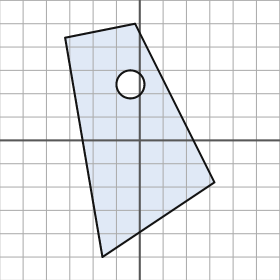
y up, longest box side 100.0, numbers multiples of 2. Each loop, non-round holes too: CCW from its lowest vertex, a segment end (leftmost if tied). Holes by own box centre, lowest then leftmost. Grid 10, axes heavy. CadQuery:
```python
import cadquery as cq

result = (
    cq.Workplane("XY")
    .moveTo(-16.0, -50.0)
    .lineTo(32.0, -18.0)
    .lineTo(-2.0, 50.0)
    .lineTo(-32.0, 44.0)
    .close()
    .moveTo(-4.0, 24.0)
    .circle(6.0)
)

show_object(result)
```